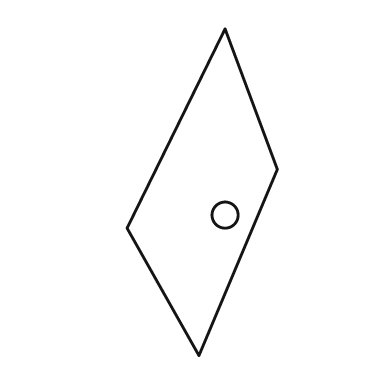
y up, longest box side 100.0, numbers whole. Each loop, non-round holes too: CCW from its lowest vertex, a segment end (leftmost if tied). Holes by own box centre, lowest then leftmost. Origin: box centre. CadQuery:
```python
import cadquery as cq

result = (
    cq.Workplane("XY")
    .moveTo(-1.0, -50.0)
    .lineTo(23.0, 7.0)
    .lineTo(7.0, 50.0)
    .lineTo(-23.0, -11.0)
    .close()
    .moveTo(7.0, -7.0)
    .circle(4.0)
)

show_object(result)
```